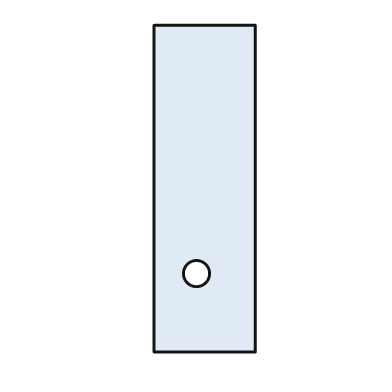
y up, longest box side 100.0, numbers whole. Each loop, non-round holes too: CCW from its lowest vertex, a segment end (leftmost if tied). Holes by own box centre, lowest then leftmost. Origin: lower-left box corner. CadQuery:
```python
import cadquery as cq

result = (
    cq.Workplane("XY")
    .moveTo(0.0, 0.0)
    .lineTo(31.0, 0.0)
    .lineTo(31.0, 100.0)
    .lineTo(0.0, 100.0)
    .close()
    .moveTo(13.0, 24.0)
    .circle(4.0)
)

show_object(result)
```